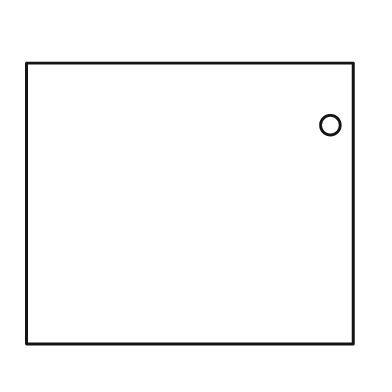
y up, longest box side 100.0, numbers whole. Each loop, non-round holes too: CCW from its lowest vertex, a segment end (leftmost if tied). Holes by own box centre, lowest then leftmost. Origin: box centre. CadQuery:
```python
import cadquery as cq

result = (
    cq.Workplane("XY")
    .moveTo(-50.0, -43.0)
    .lineTo(50.0, -43.0)
    .lineTo(50.0, 43.0)
    .lineTo(-50.0, 43.0)
    .close()
    .moveTo(43.0, 24.0)
    .circle(3.0)
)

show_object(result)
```